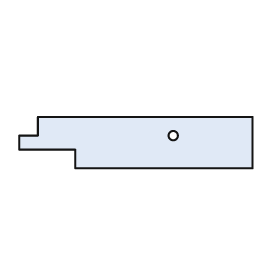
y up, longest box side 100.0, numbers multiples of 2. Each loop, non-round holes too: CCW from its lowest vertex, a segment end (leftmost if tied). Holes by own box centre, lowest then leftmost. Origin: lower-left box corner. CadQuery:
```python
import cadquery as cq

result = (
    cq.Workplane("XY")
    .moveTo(24.0, 0.0)
    .lineTo(100.0, 0.0)
    .lineTo(100.0, 22.0)
    .lineTo(8.0, 22.0)
    .lineTo(8.0, 14.0)
    .lineTo(0.0, 14.0)
    .lineTo(0.0, 8.0)
    .lineTo(24.0, 8.0)
    .close()
    .moveTo(66.0, 14.0)
    .circle(2.0)
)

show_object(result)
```